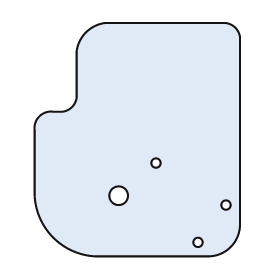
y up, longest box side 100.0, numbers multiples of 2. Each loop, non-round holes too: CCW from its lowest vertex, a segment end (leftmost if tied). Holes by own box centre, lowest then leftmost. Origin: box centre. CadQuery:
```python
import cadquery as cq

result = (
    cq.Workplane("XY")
    .moveTo(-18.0, -50.0)
    .lineTo(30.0, -50.0)
    .threePointArc((40.0, -46.0), (44.0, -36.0))
    .lineTo(44.0, 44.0)
    .threePointArc((42.0, 48.0), (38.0, 50.0))
    .lineTo(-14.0, 50.0)
    .threePointArc((-22.0, 46.0), (-26.0, 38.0))
    .lineTo(-26.0, 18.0)
    .threePointArc((-28.0, 14.0), (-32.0, 12.0))
    .lineTo(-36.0, 12.0)
    .threePointArc((-42.0, 10.0), (-44.0, 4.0))
    .lineTo(-44.0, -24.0)
    .threePointArc((-36.0, -42.0), (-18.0, -50.0))
    .close()
    .moveTo(26.0, -44.0)
    .circle(2.0)
    .moveTo(38.0, -28.0)
    .circle(2.0)
    .moveTo(-8.0, -24.0)
    .circle(4.0)
    .moveTo(8.0, -10.0)
    .circle(2.0)
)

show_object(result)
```